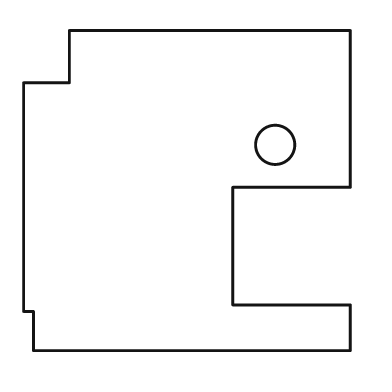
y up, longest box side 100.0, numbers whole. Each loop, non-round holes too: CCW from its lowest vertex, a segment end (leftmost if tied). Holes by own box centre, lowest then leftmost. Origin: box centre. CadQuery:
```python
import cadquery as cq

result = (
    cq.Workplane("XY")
    .moveTo(-47.0, -49.0)
    .lineTo(50.0, -49.0)
    .lineTo(50.0, -35.0)
    .lineTo(14.0, -35.0)
    .lineTo(14.0, 1.0)
    .lineTo(50.0, 1.0)
    .lineTo(50.0, 49.0)
    .lineTo(-36.0, 49.0)
    .lineTo(-36.0, 33.0)
    .lineTo(-50.0, 33.0)
    .lineTo(-50.0, -37.0)
    .lineTo(-47.0, -37.0)
    .close()
    .moveTo(27.0, 14.0)
    .circle(6.0)
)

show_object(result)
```